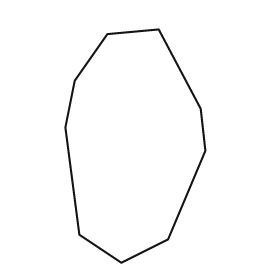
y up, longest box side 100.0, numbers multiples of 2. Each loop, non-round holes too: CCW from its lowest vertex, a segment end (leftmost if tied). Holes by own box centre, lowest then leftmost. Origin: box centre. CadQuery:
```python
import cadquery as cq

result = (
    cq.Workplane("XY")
    .moveTo(-6.0, -50.0)
    .lineTo(14.0, -40.0)
    .lineTo(30.0, -2.0)
    .lineTo(28.0, 16.0)
    .lineTo(10.0, 50.0)
    .lineTo(-12.0, 48.0)
    .lineTo(-26.0, 28.0)
    .lineTo(-30.0, 8.0)
    .lineTo(-24.0, -38.0)
    .close()
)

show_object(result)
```